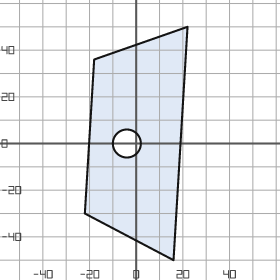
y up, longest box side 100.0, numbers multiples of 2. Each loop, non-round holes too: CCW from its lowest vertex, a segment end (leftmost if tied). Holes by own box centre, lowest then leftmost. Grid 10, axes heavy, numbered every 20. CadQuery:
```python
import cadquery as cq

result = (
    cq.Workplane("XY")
    .moveTo(16.0, -50.0)
    .lineTo(22.0, 50.0)
    .lineTo(-18.0, 36.0)
    .lineTo(-22.0, -30.0)
    .close()
    .moveTo(-4.0, 0.0)
    .circle(6.0)
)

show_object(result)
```